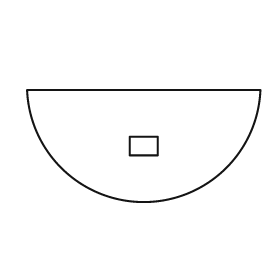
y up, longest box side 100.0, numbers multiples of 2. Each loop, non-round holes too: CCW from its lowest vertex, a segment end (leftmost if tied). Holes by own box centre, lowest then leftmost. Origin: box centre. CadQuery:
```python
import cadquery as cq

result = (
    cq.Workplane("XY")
    .moveTo(-50.0, 24.0)
    .threePointArc((0.0, -24.0), (50.0, 24.0))
    .close()
    .moveTo(-6.0, -4.0)
    .lineTo(6.0, -4.0)
    .lineTo(6.0, 4.0)
    .lineTo(-6.0, 4.0)
    .close()
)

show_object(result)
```